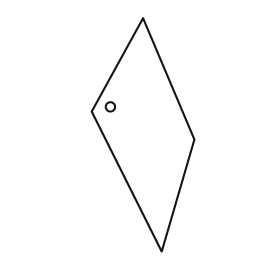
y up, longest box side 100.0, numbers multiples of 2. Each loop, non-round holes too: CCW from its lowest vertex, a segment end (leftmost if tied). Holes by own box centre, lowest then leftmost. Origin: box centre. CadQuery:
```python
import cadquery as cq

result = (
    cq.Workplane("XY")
    .moveTo(8.0, -50.0)
    .lineTo(22.0, -2.0)
    .lineTo(0.0, 50.0)
    .lineTo(-22.0, 10.0)
    .close()
    .moveTo(-14.0, 12.0)
    .circle(2.0)
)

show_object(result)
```